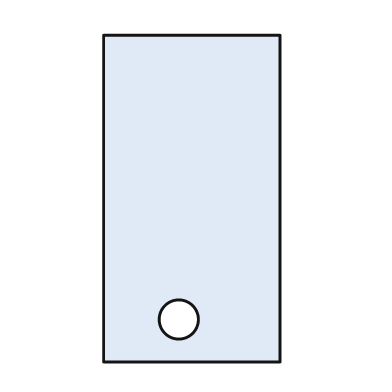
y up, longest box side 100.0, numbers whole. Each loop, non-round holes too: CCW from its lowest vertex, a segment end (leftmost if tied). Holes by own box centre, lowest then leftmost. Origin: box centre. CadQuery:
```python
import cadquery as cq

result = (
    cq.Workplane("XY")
    .moveTo(-27.0, -50.0)
    .lineTo(27.0, -50.0)
    .lineTo(27.0, 50.0)
    .lineTo(-27.0, 50.0)
    .close()
    .moveTo(-4.0, -37.0)
    .circle(6.0)
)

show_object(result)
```